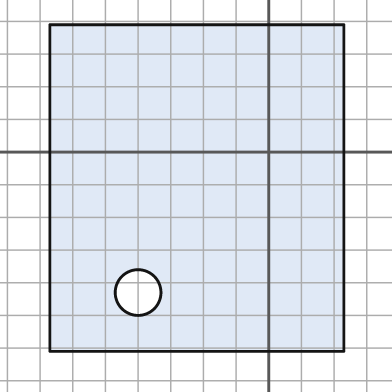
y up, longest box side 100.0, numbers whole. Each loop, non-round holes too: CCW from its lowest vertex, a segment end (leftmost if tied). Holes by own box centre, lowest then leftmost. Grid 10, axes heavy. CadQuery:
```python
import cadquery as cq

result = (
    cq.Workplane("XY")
    .moveTo(-67.0, -61.0)
    .lineTo(23.0, -61.0)
    .lineTo(23.0, 39.0)
    .lineTo(-67.0, 39.0)
    .close()
    .moveTo(-40.0, -43.0)
    .circle(7.0)
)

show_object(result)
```